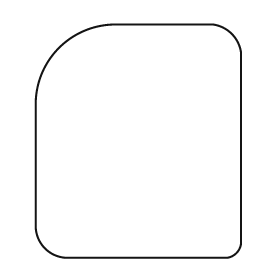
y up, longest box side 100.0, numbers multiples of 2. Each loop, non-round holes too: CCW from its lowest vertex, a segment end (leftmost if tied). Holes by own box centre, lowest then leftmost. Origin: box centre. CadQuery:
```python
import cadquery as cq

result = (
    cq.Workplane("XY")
    .moveTo(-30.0, -50.0)
    .lineTo(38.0, -50.0)
    .threePointArc((42.0, -48.0), (44.0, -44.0))
    .lineTo(44.0, 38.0)
    .threePointArc((40.0, 46.0), (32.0, 50.0))
    .lineTo(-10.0, 50.0)
    .threePointArc((-34.0, 40.0), (-44.0, 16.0))
    .lineTo(-44.0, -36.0)
    .threePointArc((-40.0, -46.0), (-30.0, -50.0))
    .close()
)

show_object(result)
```